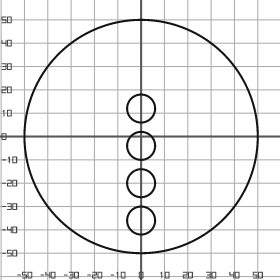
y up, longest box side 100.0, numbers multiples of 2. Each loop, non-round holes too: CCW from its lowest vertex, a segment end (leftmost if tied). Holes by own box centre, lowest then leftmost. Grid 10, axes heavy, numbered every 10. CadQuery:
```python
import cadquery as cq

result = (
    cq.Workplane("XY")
    .moveTo(0.0, 0.0)
    .circle(50.0)
    .moveTo(0.0, -36.0)
    .circle(6.0)
    .moveTo(0.0, -20.0)
    .circle(6.0)
    .moveTo(0.0, -4.0)
    .circle(6.0)
    .moveTo(0.0, 12.0)
    .circle(6.0)
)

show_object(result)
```